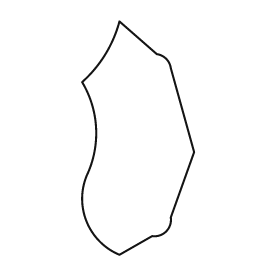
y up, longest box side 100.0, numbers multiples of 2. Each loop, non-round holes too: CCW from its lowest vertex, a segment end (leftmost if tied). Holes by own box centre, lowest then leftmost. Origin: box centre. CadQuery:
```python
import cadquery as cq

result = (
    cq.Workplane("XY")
    .moveTo(-8.0, -50.0)
    .lineTo(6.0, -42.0)
    .threePointArc((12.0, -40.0), (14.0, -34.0))
    .lineTo(24.0, -6.0)
    .lineTo(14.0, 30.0)
    .threePointArc((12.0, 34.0), (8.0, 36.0))
    .lineTo(-8.0, 50.0)
    .threePointArc((-14.0, 36.0), (-24.0, 24.0))
    .threePointArc((-18.0, 4.0), (-22.0, -16.0))
    .threePointArc((-22.0, -36.0), (-8.0, -50.0))
    .close()
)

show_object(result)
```